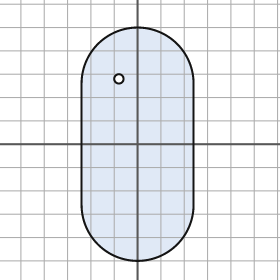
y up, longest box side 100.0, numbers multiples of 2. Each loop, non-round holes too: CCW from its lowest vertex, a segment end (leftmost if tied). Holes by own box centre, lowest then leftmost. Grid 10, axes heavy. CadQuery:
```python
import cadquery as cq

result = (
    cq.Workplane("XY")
    .moveTo(-24.0, -26.0)
    .threePointArc((0.0, -50.0), (24.0, -26.0))
    .lineTo(24.0, 26.0)
    .threePointArc((0.0, 50.0), (-24.0, 26.0))
    .close()
    .moveTo(-8.0, 28.0)
    .circle(2.0)
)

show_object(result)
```